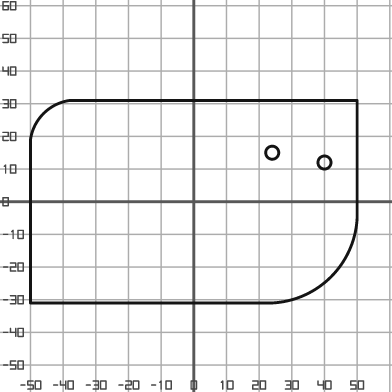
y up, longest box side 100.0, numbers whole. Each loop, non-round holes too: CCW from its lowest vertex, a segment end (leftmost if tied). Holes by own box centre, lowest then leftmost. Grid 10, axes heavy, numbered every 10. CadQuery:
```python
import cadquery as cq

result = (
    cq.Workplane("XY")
    .moveTo(-50.0, -31.0)
    .lineTo(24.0, -31.0)
    .threePointArc((42.0, -23.0), (50.0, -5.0))
    .lineTo(50.0, 31.0)
    .lineTo(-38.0, 31.0)
    .threePointArc((-46.0, 27.0), (-50.0, 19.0))
    .close()
    .moveTo(40.0, 12.0)
    .circle(2.0)
    .moveTo(24.0, 15.0)
    .circle(2.0)
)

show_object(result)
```